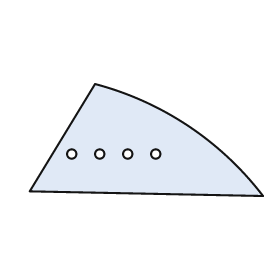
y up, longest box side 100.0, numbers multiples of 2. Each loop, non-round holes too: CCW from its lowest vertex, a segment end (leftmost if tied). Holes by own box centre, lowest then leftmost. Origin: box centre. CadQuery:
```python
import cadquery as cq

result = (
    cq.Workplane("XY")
    .moveTo(50.0, -24.0)
    .threePointArc((18.0, 6.0), (-22.0, 24.0))
    .lineTo(-50.0, -22.0)
    .close()
    .moveTo(-32.0, -6.0)
    .circle(2.0)
    .moveTo(-20.0, -6.0)
    .circle(2.0)
    .moveTo(-8.0, -6.0)
    .circle(2.0)
    .moveTo(4.0, -6.0)
    .circle(2.0)
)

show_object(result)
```